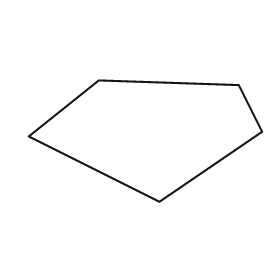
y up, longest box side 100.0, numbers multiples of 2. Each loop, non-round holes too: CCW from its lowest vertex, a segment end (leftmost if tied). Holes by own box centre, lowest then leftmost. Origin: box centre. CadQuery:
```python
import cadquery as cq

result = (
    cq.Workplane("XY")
    .moveTo(6.0, -26.0)
    .lineTo(50.0, 4.0)
    .lineTo(40.0, 24.0)
    .lineTo(-20.0, 26.0)
    .lineTo(-50.0, 2.0)
    .close()
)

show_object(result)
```